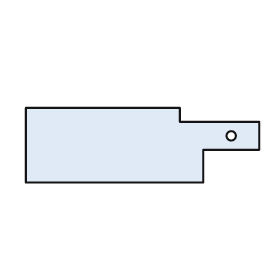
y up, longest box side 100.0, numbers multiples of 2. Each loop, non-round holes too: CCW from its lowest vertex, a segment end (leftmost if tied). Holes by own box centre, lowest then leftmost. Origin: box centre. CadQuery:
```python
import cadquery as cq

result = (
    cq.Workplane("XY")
    .moveTo(-50.0, -16.0)
    .lineTo(26.0, -16.0)
    .lineTo(26.0, -2.0)
    .lineTo(50.0, -2.0)
    .lineTo(50.0, 10.0)
    .lineTo(16.0, 10.0)
    .lineTo(16.0, 16.0)
    .lineTo(-50.0, 16.0)
    .close()
    .moveTo(38.0, 4.0)
    .circle(2.0)
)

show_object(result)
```